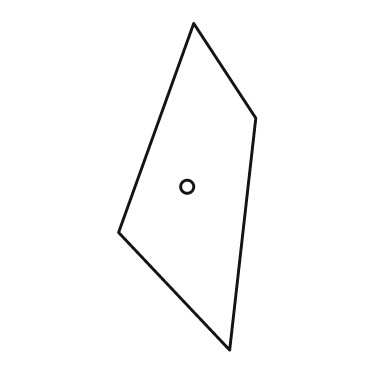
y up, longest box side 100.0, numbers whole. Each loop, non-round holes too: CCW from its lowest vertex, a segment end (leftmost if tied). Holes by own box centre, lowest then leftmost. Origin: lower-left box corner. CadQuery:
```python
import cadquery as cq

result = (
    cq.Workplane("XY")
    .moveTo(34.0, 0.0)
    .lineTo(42.0, 71.0)
    .lineTo(23.0, 100.0)
    .lineTo(0.0, 36.0)
    .close()
    .moveTo(21.0, 50.0)
    .circle(2.0)
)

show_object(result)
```